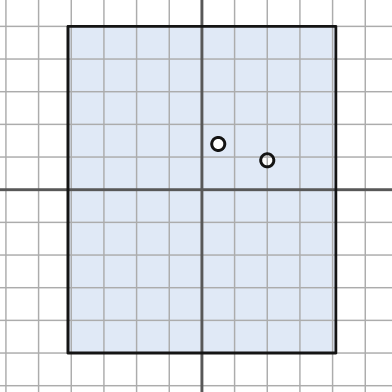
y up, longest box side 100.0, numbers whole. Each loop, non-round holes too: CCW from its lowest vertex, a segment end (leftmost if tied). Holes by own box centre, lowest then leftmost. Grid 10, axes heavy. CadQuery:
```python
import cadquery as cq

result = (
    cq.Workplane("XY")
    .moveTo(-41.0, -50.0)
    .lineTo(41.0, -50.0)
    .lineTo(41.0, 50.0)
    .lineTo(-41.0, 50.0)
    .close()
    .moveTo(20.0, 9.0)
    .circle(2.0)
    .moveTo(5.0, 14.0)
    .circle(2.0)
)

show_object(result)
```